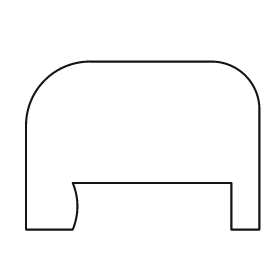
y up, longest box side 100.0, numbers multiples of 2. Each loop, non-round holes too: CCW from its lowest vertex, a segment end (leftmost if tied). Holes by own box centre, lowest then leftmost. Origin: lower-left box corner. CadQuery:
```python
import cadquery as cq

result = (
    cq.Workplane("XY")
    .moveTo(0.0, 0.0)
    .lineTo(20.0, 0.0)
    .threePointArc((22.0, 10.0), (20.0, 20.0))
    .lineTo(88.0, 20.0)
    .lineTo(88.0, 0.0)
    .lineTo(100.0, 0.0)
    .lineTo(100.0, 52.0)
    .threePointArc((94.0, 66.0), (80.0, 72.0))
    .lineTo(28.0, 72.0)
    .threePointArc((8.0, 64.0), (0.0, 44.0))
    .close()
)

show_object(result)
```